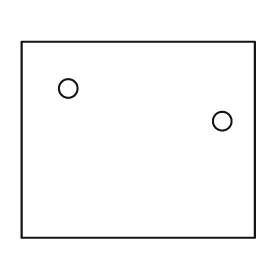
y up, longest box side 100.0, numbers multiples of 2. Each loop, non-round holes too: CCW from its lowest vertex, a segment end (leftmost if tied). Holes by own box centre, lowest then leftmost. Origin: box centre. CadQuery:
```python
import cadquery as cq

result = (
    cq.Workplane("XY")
    .moveTo(-50.0, -42.0)
    .lineTo(50.0, -42.0)
    .lineTo(50.0, 42.0)
    .lineTo(-50.0, 42.0)
    .close()
    .moveTo(36.0, 8.0)
    .circle(4.0)
    .moveTo(-30.0, 22.0)
    .circle(4.0)
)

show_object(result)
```